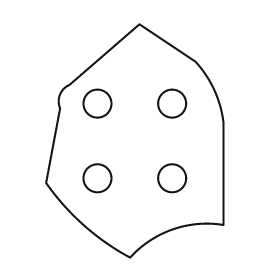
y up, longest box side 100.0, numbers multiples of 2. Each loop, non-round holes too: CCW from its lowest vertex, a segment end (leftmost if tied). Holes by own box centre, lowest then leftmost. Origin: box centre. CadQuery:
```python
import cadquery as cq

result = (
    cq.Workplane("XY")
    .moveTo(-2.0, -50.0)
    .threePointArc((16.0, -38.0), (38.0, -36.0))
    .lineTo(38.0, 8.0)
    .threePointArc((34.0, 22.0), (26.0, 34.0))
    .lineTo(2.0, 50.0)
    .lineTo(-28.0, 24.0)
    .threePointArc((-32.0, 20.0), (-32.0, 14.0))
    .lineTo(-38.0, -18.0)
    .threePointArc((-22.0, -36.0), (-2.0, -50.0))
    .close()
    .moveTo(-16.0, -16.0)
    .circle(6.0)
    .moveTo(16.0, -16.0)
    .circle(6.0)
    .moveTo(-16.0, 16.0)
    .circle(6.0)
    .moveTo(16.0, 16.0)
    .circle(6.0)
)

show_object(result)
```